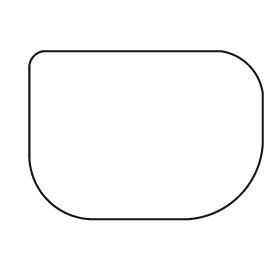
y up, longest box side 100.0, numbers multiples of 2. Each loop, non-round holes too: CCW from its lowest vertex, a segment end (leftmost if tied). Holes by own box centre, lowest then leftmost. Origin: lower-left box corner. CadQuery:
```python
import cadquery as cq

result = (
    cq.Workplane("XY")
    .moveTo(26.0, 0.0)
    .lineTo(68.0, 0.0)
    .threePointArc((90.0, 10.0), (100.0, 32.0))
    .lineTo(100.0, 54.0)
    .threePointArc((94.0, 66.0), (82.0, 72.0))
    .lineTo(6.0, 72.0)
    .threePointArc((2.0, 70.0), (0.0, 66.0))
    .lineTo(0.0, 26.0)
    .threePointArc((8.0, 8.0), (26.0, 0.0))
    .close()
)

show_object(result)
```